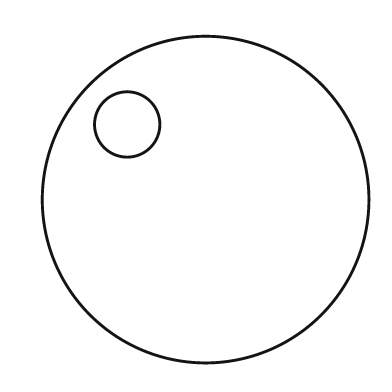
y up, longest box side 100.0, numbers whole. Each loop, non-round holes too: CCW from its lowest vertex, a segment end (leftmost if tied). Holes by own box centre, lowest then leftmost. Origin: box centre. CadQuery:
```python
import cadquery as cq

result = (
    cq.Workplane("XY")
    .moveTo(0.0, 0.0)
    .circle(50.0)
    .moveTo(-24.0, 23.0)
    .circle(10.0)
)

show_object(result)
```